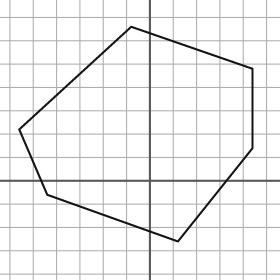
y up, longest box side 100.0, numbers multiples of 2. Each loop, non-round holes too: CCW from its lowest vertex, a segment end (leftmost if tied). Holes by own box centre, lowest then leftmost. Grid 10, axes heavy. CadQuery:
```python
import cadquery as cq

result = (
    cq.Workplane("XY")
    .moveTo(12.0, -26.0)
    .lineTo(44.0, 14.0)
    .lineTo(44.0, 48.0)
    .lineTo(-8.0, 66.0)
    .lineTo(-56.0, 22.0)
    .lineTo(-44.0, -6.0)
    .close()
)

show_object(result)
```